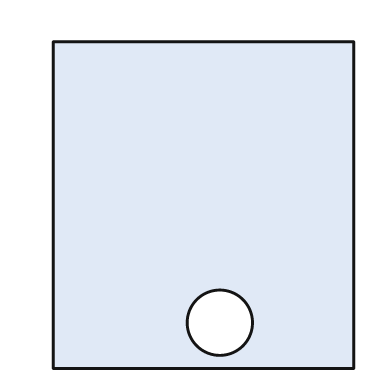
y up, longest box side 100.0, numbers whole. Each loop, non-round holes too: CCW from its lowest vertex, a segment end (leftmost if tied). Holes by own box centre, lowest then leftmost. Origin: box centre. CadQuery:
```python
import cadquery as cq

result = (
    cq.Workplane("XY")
    .moveTo(-46.0, -50.0)
    .lineTo(46.0, -50.0)
    .lineTo(46.0, 50.0)
    .lineTo(-46.0, 50.0)
    .close()
    .moveTo(5.0, -36.0)
    .circle(10.0)
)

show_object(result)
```